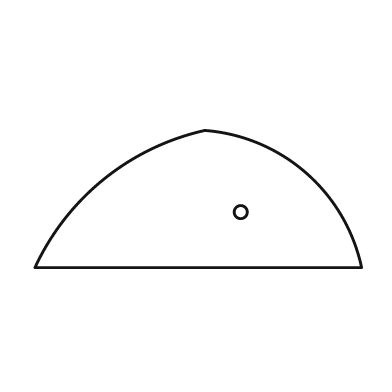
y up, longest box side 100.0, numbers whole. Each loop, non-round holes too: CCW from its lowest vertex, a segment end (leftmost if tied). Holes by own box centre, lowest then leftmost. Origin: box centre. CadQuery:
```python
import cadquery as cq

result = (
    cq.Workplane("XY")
    .moveTo(-50.0, -21.0)
    .lineTo(50.0, -21.0)
    .threePointArc((33.0, 8.0), (2.0, 21.0))
    .threePointArc((-29.0, 6.0), (-50.0, -21.0))
    .close()
    .moveTo(13.0, -4.0)
    .circle(2.0)
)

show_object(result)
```